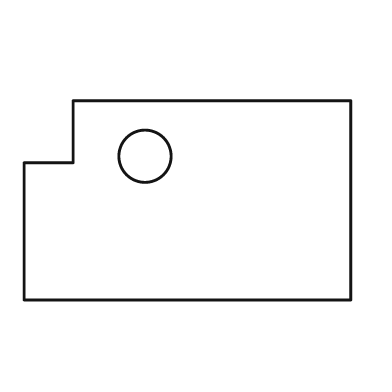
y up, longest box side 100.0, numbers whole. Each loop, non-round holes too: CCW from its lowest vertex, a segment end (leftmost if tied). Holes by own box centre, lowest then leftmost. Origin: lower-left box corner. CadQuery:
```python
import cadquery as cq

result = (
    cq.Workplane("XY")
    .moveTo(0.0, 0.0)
    .lineTo(100.0, 0.0)
    .lineTo(100.0, 61.0)
    .lineTo(15.0, 61.0)
    .lineTo(15.0, 42.0)
    .lineTo(0.0, 42.0)
    .close()
    .moveTo(37.0, 44.0)
    .circle(8.0)
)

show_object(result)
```